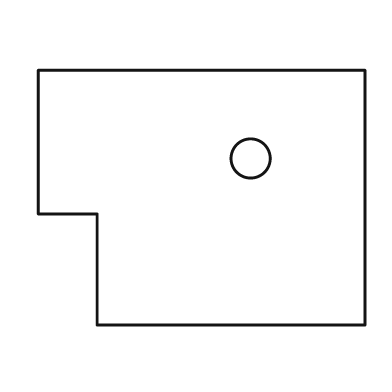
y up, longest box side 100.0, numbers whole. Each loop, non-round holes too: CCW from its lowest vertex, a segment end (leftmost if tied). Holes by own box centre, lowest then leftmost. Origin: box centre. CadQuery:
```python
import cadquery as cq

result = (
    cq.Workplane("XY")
    .moveTo(-32.0, -39.0)
    .lineTo(50.0, -39.0)
    .lineTo(50.0, 39.0)
    .lineTo(-50.0, 39.0)
    .lineTo(-50.0, -5.0)
    .lineTo(-32.0, -5.0)
    .close()
    .moveTo(15.0, 12.0)
    .circle(6.0)
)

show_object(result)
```